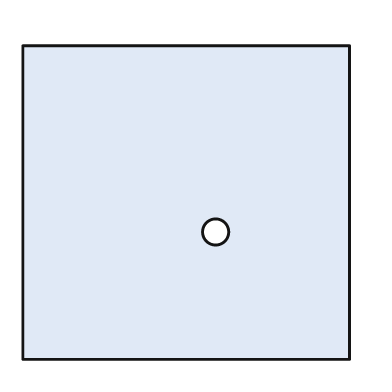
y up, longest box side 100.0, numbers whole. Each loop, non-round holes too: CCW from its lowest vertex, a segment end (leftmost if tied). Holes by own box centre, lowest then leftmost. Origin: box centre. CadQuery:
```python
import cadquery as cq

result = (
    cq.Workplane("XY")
    .moveTo(-50.0, -48.0)
    .lineTo(50.0, -48.0)
    .lineTo(50.0, 48.0)
    .lineTo(-50.0, 48.0)
    .close()
    .moveTo(9.0, -9.0)
    .circle(4.0)
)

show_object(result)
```